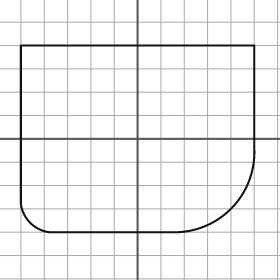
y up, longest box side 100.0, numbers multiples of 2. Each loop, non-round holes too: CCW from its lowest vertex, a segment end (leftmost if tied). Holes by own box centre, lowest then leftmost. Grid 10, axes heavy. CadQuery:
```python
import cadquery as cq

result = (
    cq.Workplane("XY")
    .moveTo(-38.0, -40.0)
    .lineTo(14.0, -40.0)
    .threePointArc((40.0, -30.0), (50.0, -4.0))
    .lineTo(50.0, 40.0)
    .lineTo(-50.0, 40.0)
    .lineTo(-50.0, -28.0)
    .threePointArc((-46.0, -36.0), (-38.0, -40.0))
    .close()
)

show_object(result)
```